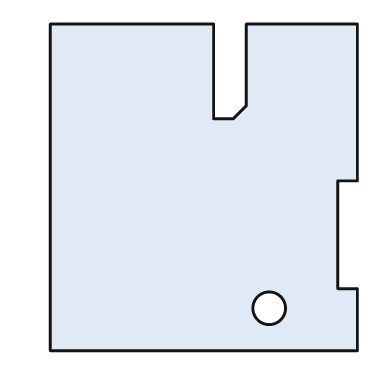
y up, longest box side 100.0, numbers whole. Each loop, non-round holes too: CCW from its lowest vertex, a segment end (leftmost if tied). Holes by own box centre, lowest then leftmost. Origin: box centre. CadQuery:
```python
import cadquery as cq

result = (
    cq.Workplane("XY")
    .moveTo(-47.0, -50.0)
    .lineTo(47.0, -50.0)
    .lineTo(47.0, -31.0)
    .lineTo(41.0, -31.0)
    .lineTo(41.0, 2.0)
    .lineTo(47.0, 2.0)
    .lineTo(47.0, 50.0)
    .lineTo(13.0, 50.0)
    .lineTo(13.0, 25.0)
    .lineTo(9.0, 21.0)
    .lineTo(3.0, 21.0)
    .lineTo(3.0, 50.0)
    .lineTo(-47.0, 50.0)
    .close()
    .moveTo(20.0, -37.0)
    .circle(5.0)
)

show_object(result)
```